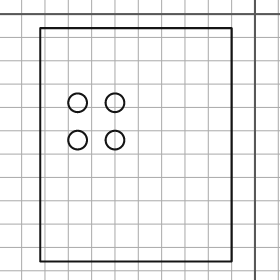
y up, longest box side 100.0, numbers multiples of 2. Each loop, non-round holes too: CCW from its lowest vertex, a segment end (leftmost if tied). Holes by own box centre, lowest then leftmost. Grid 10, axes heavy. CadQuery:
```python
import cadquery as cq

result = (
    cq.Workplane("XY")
    .moveTo(-92.0, -106.0)
    .lineTo(-10.0, -106.0)
    .lineTo(-10.0, -6.0)
    .lineTo(-92.0, -6.0)
    .close()
    .moveTo(-76.0, -54.0)
    .circle(4.0)
    .moveTo(-60.0, -54.0)
    .circle(4.0)
    .moveTo(-76.0, -38.0)
    .circle(4.0)
    .moveTo(-60.0, -38.0)
    .circle(4.0)
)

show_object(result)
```